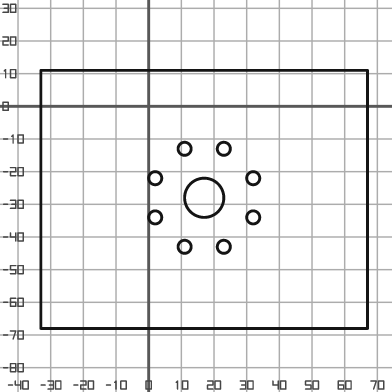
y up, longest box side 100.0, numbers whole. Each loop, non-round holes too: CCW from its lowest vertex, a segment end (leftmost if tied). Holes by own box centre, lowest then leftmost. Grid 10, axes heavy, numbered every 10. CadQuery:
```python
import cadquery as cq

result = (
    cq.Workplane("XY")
    .moveTo(-33.0, -68.0)
    .lineTo(67.0, -68.0)
    .lineTo(67.0, 11.0)
    .lineTo(-33.0, 11.0)
    .close()
    .moveTo(11.0, -43.0)
    .circle(2.0)
    .moveTo(23.0, -43.0)
    .circle(2.0)
    .moveTo(2.0, -34.0)
    .circle(2.0)
    .moveTo(32.0, -34.0)
    .circle(2.0)
    .moveTo(17.0, -28.0)
    .circle(6.0)
    .moveTo(2.0, -22.0)
    .circle(2.0)
    .moveTo(32.0, -22.0)
    .circle(2.0)
    .moveTo(11.0, -13.0)
    .circle(2.0)
    .moveTo(23.0, -13.0)
    .circle(2.0)
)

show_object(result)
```